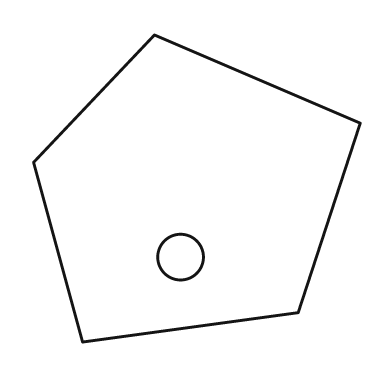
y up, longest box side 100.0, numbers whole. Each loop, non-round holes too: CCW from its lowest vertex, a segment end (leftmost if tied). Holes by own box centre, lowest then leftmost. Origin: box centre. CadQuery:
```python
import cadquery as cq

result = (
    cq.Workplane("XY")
    .moveTo(-35.0, -47.0)
    .lineTo(31.0, -38.0)
    .lineTo(50.0, 20.0)
    .lineTo(-13.0, 47.0)
    .lineTo(-50.0, 8.0)
    .close()
    .moveTo(-5.0, -21.0)
    .circle(7.0)
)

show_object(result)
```